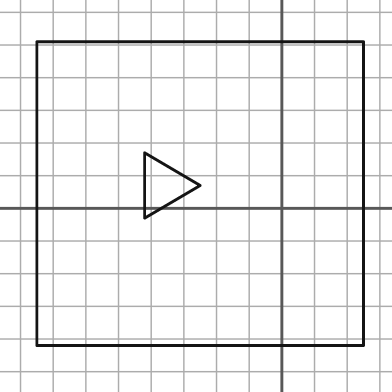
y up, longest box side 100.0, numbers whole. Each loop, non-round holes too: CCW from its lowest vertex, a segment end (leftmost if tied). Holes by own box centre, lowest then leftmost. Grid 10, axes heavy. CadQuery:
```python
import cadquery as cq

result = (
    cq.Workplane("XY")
    .moveTo(-75.0, -42.0)
    .lineTo(25.0, -42.0)
    .lineTo(25.0, 51.0)
    .lineTo(-75.0, 51.0)
    .close()
    .moveTo(-42.0, -3.0)
    .lineTo(-25.0, 7.0)
    .lineTo(-42.0, 17.0)
    .close()
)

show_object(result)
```